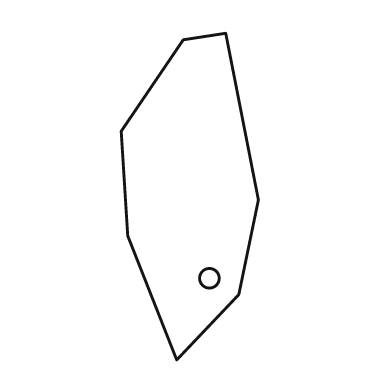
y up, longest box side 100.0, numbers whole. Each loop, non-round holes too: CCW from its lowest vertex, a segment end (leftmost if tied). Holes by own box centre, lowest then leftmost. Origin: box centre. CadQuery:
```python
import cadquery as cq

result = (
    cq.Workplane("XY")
    .moveTo(-4.0, -50.0)
    .lineTo(15.0, -30.0)
    .lineTo(21.0, -1.0)
    .lineTo(11.0, 50.0)
    .lineTo(-2.0, 48.0)
    .lineTo(-21.0, 20.0)
    .lineTo(-19.0, -12.0)
    .close()
    .moveTo(6.0, -25.0)
    .circle(3.0)
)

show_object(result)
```